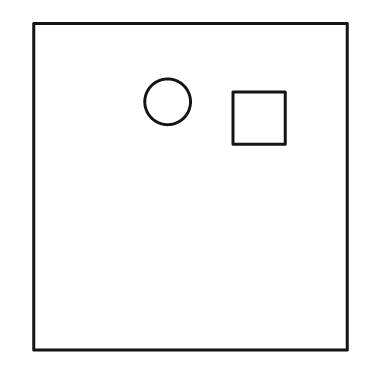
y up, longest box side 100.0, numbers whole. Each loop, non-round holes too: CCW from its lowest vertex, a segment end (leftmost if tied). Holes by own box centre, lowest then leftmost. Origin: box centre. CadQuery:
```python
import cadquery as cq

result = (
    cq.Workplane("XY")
    .moveTo(-48.0, -50.0)
    .lineTo(48.0, -50.0)
    .lineTo(48.0, 50.0)
    .lineTo(-48.0, 50.0)
    .close()
    .moveTo(13.0, 13.0)
    .lineTo(29.0, 13.0)
    .lineTo(29.0, 29.0)
    .lineTo(13.0, 29.0)
    .close()
    .moveTo(-7.0, 26.0)
    .circle(7.0)
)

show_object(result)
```